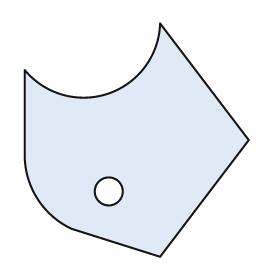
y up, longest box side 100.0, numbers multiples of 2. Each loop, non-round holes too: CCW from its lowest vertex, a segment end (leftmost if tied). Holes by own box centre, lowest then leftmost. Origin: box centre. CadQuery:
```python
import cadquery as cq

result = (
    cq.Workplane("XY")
    .moveTo(10.0, -50.0)
    .lineTo(48.0, 0.0)
    .lineTo(10.0, 50.0)
    .threePointArc((-12.0, 20.0), (-48.0, 30.0))
    .lineTo(-48.0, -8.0)
    .threePointArc((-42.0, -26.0), (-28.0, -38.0))
    .close()
    .moveTo(-12.0, -22.0)
    .circle(6.0)
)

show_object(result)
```